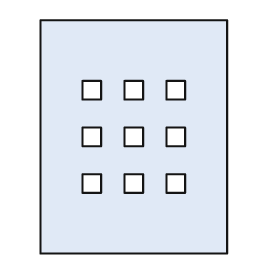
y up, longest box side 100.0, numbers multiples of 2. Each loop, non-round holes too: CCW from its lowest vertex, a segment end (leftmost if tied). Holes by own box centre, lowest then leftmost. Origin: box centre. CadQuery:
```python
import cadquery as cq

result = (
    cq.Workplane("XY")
    .moveTo(-40.0, -50.0)
    .lineTo(40.0, -50.0)
    .lineTo(40.0, 50.0)
    .lineTo(-40.0, 50.0)
    .close()
    .moveTo(-22.0, -24.0)
    .lineTo(-14.0, -24.0)
    .lineTo(-14.0, -16.0)
    .lineTo(-22.0, -16.0)
    .close()
    .moveTo(-4.0, -24.0)
    .lineTo(4.0, -24.0)
    .lineTo(4.0, -16.0)
    .lineTo(-4.0, -16.0)
    .close()
    .moveTo(14.0, -24.0)
    .lineTo(22.0, -24.0)
    .lineTo(22.0, -16.0)
    .lineTo(14.0, -16.0)
    .close()
    .moveTo(-22.0, -4.0)
    .lineTo(-14.0, -4.0)
    .lineTo(-14.0, 4.0)
    .lineTo(-22.0, 4.0)
    .close()
    .moveTo(-4.0, -4.0)
    .lineTo(4.0, -4.0)
    .lineTo(4.0, 4.0)
    .lineTo(-4.0, 4.0)
    .close()
    .moveTo(14.0, -4.0)
    .lineTo(22.0, -4.0)
    .lineTo(22.0, 4.0)
    .lineTo(14.0, 4.0)
    .close()
    .moveTo(-22.0, 16.0)
    .lineTo(-14.0, 16.0)
    .lineTo(-14.0, 24.0)
    .lineTo(-22.0, 24.0)
    .close()
    .moveTo(-4.0, 16.0)
    .lineTo(4.0, 16.0)
    .lineTo(4.0, 24.0)
    .lineTo(-4.0, 24.0)
    .close()
    .moveTo(14.0, 16.0)
    .lineTo(22.0, 16.0)
    .lineTo(22.0, 24.0)
    .lineTo(14.0, 24.0)
    .close()
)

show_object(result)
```